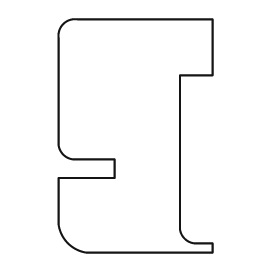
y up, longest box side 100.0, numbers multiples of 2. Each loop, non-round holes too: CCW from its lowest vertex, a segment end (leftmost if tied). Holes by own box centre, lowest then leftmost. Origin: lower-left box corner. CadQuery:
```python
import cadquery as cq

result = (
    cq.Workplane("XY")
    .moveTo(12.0, 0.0)
    .lineTo(66.0, 0.0)
    .lineTo(66.0, 4.0)
    .lineTo(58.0, 4.0)
    .threePointArc((54.0, 6.0), (52.0, 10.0))
    .lineTo(52.0, 76.0)
    .lineTo(66.0, 76.0)
    .lineTo(66.0, 100.0)
    .lineTo(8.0, 100.0)
    .threePointArc((2.0, 98.0), (0.0, 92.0))
    .lineTo(0.0, 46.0)
    .threePointArc((2.0, 42.0), (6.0, 40.0))
    .lineTo(24.0, 40.0)
    .lineTo(24.0, 32.0)
    .lineTo(0.0, 32.0)
    .lineTo(0.0, 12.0)
    .threePointArc((4.0, 4.0), (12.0, 0.0))
    .close()
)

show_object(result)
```